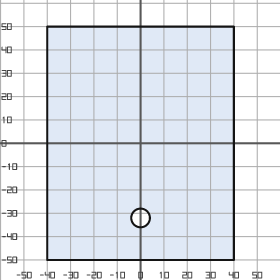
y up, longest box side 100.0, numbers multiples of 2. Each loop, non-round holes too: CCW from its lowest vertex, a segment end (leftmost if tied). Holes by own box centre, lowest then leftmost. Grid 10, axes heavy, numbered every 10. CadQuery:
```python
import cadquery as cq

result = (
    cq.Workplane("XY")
    .moveTo(-40.0, -50.0)
    .lineTo(40.0, -50.0)
    .lineTo(40.0, 50.0)
    .lineTo(-40.0, 50.0)
    .close()
    .moveTo(0.0, -32.0)
    .circle(4.0)
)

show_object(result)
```